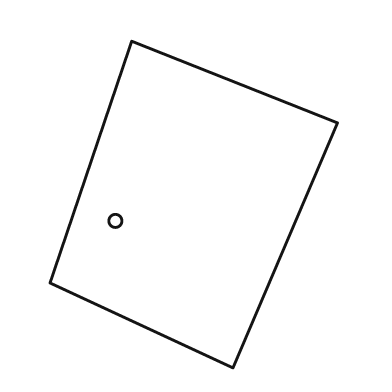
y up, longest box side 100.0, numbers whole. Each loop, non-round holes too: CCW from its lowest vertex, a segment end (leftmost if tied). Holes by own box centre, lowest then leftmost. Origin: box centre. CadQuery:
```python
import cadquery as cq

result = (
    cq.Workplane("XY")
    .moveTo(12.0, -50.0)
    .lineTo(44.0, 25.0)
    .lineTo(-19.0, 50.0)
    .lineTo(-44.0, -24.0)
    .close()
    .moveTo(-24.0, -5.0)
    .circle(2.0)
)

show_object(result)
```